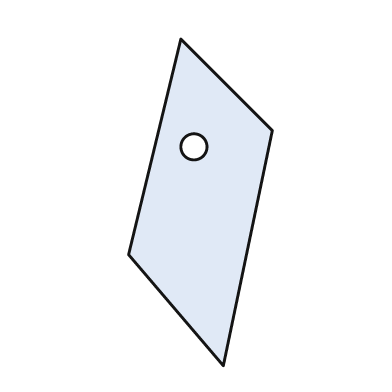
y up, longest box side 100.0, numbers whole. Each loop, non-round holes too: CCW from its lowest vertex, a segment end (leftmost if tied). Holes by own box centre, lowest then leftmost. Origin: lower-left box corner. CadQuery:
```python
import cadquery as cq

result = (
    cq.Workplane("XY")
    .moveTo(29.0, 0.0)
    .lineTo(44.0, 72.0)
    .lineTo(16.0, 100.0)
    .lineTo(0.0, 34.0)
    .close()
    .moveTo(20.0, 67.0)
    .circle(4.0)
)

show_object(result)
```